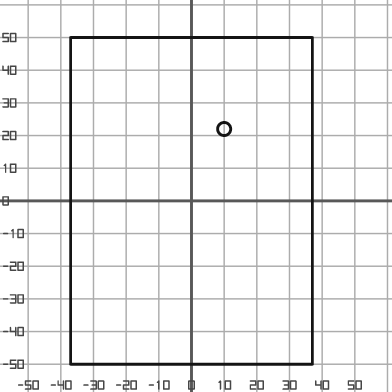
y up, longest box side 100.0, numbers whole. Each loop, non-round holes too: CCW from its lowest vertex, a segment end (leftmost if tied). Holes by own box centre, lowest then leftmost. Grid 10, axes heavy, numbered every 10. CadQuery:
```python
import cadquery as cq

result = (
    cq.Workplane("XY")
    .moveTo(-37.0, -50.0)
    .lineTo(37.0, -50.0)
    .lineTo(37.0, 50.0)
    .lineTo(-37.0, 50.0)
    .close()
    .moveTo(10.0, 22.0)
    .circle(2.0)
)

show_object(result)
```